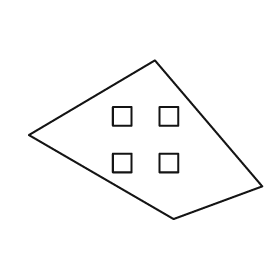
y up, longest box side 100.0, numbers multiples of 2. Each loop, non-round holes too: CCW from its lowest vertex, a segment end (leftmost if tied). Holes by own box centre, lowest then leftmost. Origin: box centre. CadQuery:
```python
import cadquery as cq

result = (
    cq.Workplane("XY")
    .moveTo(12.0, -34.0)
    .lineTo(50.0, -20.0)
    .lineTo(4.0, 34.0)
    .lineTo(-50.0, 2.0)
    .close()
    .moveTo(-14.0, -14.0)
    .lineTo(-6.0, -14.0)
    .lineTo(-6.0, -6.0)
    .lineTo(-14.0, -6.0)
    .close()
    .moveTo(6.0, -14.0)
    .lineTo(14.0, -14.0)
    .lineTo(14.0, -6.0)
    .lineTo(6.0, -6.0)
    .close()
    .moveTo(-14.0, 6.0)
    .lineTo(-6.0, 6.0)
    .lineTo(-6.0, 14.0)
    .lineTo(-14.0, 14.0)
    .close()
    .moveTo(6.0, 6.0)
    .lineTo(14.0, 6.0)
    .lineTo(14.0, 14.0)
    .lineTo(6.0, 14.0)
    .close()
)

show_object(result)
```